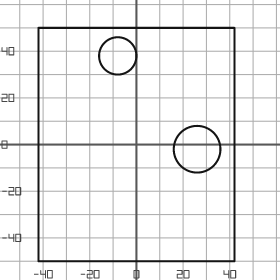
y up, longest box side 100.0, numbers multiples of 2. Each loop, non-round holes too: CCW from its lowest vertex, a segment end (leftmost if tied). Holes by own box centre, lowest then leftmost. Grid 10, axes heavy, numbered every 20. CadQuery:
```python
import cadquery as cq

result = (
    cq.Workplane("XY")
    .moveTo(-42.0, -50.0)
    .lineTo(42.0, -50.0)
    .lineTo(42.0, 50.0)
    .lineTo(-42.0, 50.0)
    .close()
    .moveTo(26.0, -2.0)
    .circle(10.0)
    .moveTo(-8.0, 38.0)
    .circle(8.0)
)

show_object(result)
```